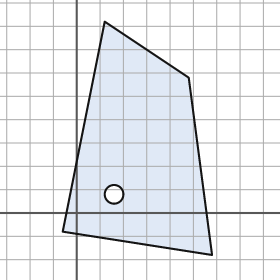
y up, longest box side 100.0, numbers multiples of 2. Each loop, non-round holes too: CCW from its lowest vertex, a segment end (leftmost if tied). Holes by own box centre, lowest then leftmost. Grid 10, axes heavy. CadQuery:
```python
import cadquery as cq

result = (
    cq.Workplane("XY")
    .moveTo(58.0, -18.0)
    .lineTo(48.0, 58.0)
    .lineTo(12.0, 82.0)
    .lineTo(-6.0, -8.0)
    .close()
    .moveTo(16.0, 8.0)
    .circle(4.0)
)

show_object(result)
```